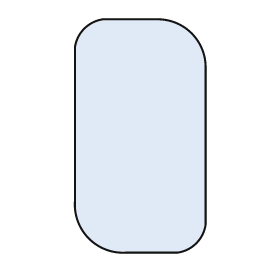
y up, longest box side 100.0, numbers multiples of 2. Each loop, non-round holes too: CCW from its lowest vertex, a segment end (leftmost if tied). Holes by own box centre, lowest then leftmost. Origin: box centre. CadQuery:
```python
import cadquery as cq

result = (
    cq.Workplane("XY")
    .moveTo(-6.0, -50.0)
    .lineTo(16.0, -50.0)
    .threePointArc((24.0, -46.0), (28.0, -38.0))
    .lineTo(28.0, 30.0)
    .threePointArc((22.0, 44.0), (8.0, 50.0))
    .lineTo(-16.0, 50.0)
    .threePointArc((-24.0, 46.0), (-28.0, 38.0))
    .lineTo(-28.0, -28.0)
    .threePointArc((-22.0, -44.0), (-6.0, -50.0))
    .close()
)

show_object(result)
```